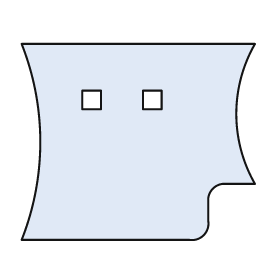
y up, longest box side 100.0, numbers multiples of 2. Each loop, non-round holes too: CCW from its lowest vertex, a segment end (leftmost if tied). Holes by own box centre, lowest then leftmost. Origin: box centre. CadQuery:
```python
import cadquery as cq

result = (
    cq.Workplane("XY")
    .moveTo(-50.0, -42.0)
    .lineTo(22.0, -42.0)
    .threePointArc((28.0, -40.0), (30.0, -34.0))
    .lineTo(30.0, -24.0)
    .threePointArc((32.0, -20.0), (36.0, -18.0))
    .lineTo(50.0, -18.0)
    .threePointArc((42.0, 12.0), (50.0, 42.0))
    .lineTo(-50.0, 42.0)
    .threePointArc((-42.0, 0.0), (-50.0, -42.0))
    .close()
    .moveTo(-24.0, 14.0)
    .lineTo(-16.0, 14.0)
    .lineTo(-16.0, 22.0)
    .lineTo(-24.0, 22.0)
    .close()
    .moveTo(2.0, 14.0)
    .lineTo(10.0, 14.0)
    .lineTo(10.0, 22.0)
    .lineTo(2.0, 22.0)
    .close()
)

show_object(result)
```